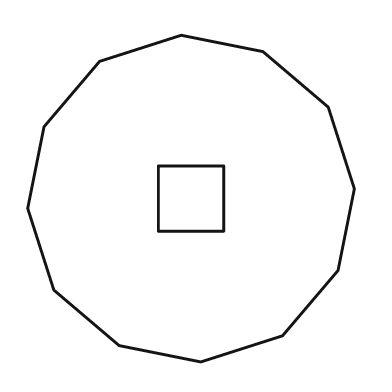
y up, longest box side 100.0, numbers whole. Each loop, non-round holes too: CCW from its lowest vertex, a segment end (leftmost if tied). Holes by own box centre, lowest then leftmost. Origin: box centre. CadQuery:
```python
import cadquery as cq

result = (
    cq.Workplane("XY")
    .moveTo(3.0, -50.0)
    .lineTo(28.0, -42.0)
    .lineTo(45.0, -22.0)
    .lineTo(50.0, 3.0)
    .lineTo(42.0, 28.0)
    .lineTo(22.0, 45.0)
    .lineTo(-3.0, 50.0)
    .lineTo(-28.0, 42.0)
    .lineTo(-45.0, 22.0)
    .lineTo(-50.0, -3.0)
    .lineTo(-42.0, -28.0)
    .lineTo(-22.0, -45.0)
    .close()
    .moveTo(-10.0, -10.0)
    .lineTo(10.0, -10.0)
    .lineTo(10.0, 10.0)
    .lineTo(-10.0, 10.0)
    .close()
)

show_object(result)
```